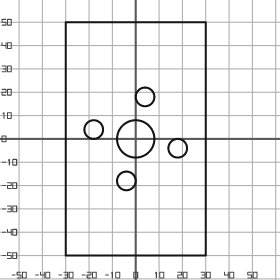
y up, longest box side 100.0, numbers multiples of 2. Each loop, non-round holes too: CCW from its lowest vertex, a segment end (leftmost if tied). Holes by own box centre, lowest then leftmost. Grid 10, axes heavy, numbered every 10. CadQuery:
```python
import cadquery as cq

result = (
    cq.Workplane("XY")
    .moveTo(-30.0, -50.0)
    .lineTo(30.0, -50.0)
    .lineTo(30.0, 50.0)
    .lineTo(-30.0, 50.0)
    .close()
    .moveTo(-4.0, -18.0)
    .circle(4.0)
    .moveTo(18.0, -4.0)
    .circle(4.0)
    .moveTo(0.0, 0.0)
    .circle(8.0)
    .moveTo(-18.0, 4.0)
    .circle(4.0)
    .moveTo(4.0, 18.0)
    .circle(4.0)
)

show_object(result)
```